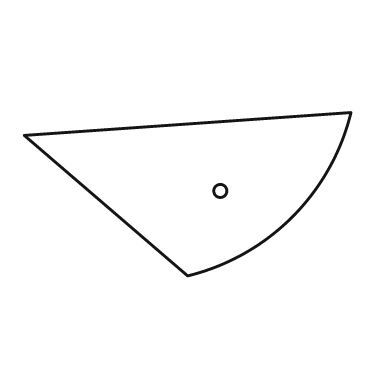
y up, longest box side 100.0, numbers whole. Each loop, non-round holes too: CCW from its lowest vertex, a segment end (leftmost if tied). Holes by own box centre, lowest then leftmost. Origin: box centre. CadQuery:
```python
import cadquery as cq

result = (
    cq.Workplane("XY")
    .moveTo(0.0, -25.0)
    .threePointArc((32.0, -7.0), (50.0, 25.0))
    .lineTo(-50.0, 18.0)
    .close()
    .moveTo(10.0, 1.0)
    .circle(2.0)
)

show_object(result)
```